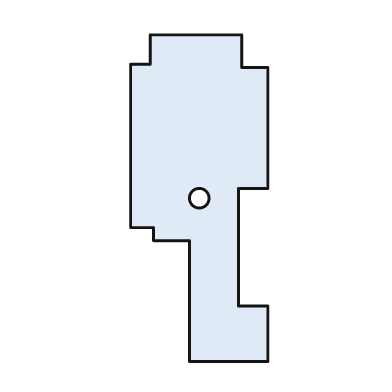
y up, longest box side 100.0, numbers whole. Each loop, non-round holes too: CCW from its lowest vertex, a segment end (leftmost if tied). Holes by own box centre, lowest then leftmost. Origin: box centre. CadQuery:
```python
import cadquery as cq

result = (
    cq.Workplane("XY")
    .moveTo(-3.0, -50.0)
    .lineTo(21.0, -50.0)
    .lineTo(21.0, -33.0)
    .lineTo(12.0, -33.0)
    .lineTo(12.0, 3.0)
    .lineTo(21.0, 3.0)
    .lineTo(21.0, 40.0)
    .lineTo(13.0, 40.0)
    .lineTo(13.0, 50.0)
    .lineTo(-15.0, 50.0)
    .lineTo(-15.0, 41.0)
    .lineTo(-21.0, 41.0)
    .lineTo(-21.0, -9.0)
    .lineTo(-14.0, -9.0)
    .lineTo(-14.0, -13.0)
    .lineTo(-3.0, -13.0)
    .close()
    .moveTo(0.0, 0.0)
    .circle(3.0)
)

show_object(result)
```